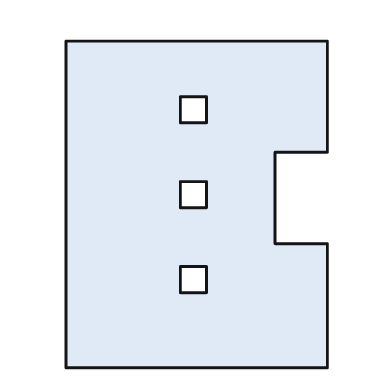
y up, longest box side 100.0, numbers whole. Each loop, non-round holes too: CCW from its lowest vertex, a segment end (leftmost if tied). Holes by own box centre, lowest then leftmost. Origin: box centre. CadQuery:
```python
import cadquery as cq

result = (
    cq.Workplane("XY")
    .moveTo(-40.0, -50.0)
    .lineTo(40.0, -50.0)
    .lineTo(40.0, -12.0)
    .lineTo(24.0, -12.0)
    .lineTo(24.0, 16.0)
    .lineTo(40.0, 16.0)
    .lineTo(40.0, 50.0)
    .lineTo(-40.0, 50.0)
    .close()
    .moveTo(-5.0, -27.0)
    .lineTo(3.0, -27.0)
    .lineTo(3.0, -19.0)
    .lineTo(-5.0, -19.0)
    .close()
    .moveTo(-5.0, -1.0)
    .lineTo(3.0, -1.0)
    .lineTo(3.0, 7.0)
    .lineTo(-5.0, 7.0)
    .close()
    .moveTo(-5.0, 25.0)
    .lineTo(3.0, 25.0)
    .lineTo(3.0, 33.0)
    .lineTo(-5.0, 33.0)
    .close()
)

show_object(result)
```